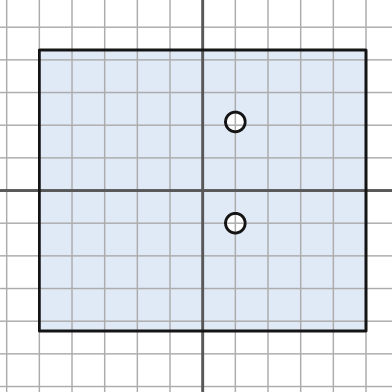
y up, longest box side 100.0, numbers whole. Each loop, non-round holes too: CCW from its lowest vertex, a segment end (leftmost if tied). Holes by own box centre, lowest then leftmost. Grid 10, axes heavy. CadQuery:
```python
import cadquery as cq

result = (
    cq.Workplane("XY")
    .moveTo(-50.0, -43.0)
    .lineTo(50.0, -43.0)
    .lineTo(50.0, 43.0)
    .lineTo(-50.0, 43.0)
    .close()
    .moveTo(10.0, -10.0)
    .circle(3.0)
    .moveTo(10.0, 21.0)
    .circle(3.0)
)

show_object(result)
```